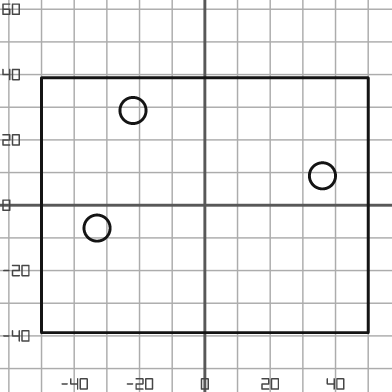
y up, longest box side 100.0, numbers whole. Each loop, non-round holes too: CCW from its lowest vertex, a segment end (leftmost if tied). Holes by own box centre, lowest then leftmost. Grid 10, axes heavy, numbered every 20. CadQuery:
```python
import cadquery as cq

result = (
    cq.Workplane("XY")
    .moveTo(-50.0, -39.0)
    .lineTo(50.0, -39.0)
    .lineTo(50.0, 39.0)
    .lineTo(-50.0, 39.0)
    .close()
    .moveTo(-33.0, -7.0)
    .circle(4.0)
    .moveTo(36.0, 9.0)
    .circle(4.0)
    .moveTo(-22.0, 29.0)
    .circle(4.0)
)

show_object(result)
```